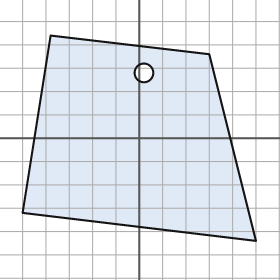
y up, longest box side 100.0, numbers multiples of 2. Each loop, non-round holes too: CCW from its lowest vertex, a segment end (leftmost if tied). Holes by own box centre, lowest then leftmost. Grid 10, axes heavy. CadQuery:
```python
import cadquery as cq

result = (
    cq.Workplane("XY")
    .moveTo(50.0, -44.0)
    .lineTo(30.0, 36.0)
    .lineTo(-38.0, 44.0)
    .lineTo(-50.0, -32.0)
    .close()
    .moveTo(2.0, 28.0)
    .circle(4.0)
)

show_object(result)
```